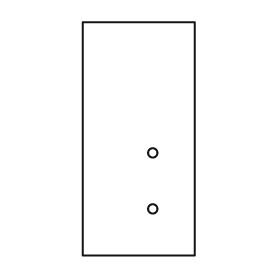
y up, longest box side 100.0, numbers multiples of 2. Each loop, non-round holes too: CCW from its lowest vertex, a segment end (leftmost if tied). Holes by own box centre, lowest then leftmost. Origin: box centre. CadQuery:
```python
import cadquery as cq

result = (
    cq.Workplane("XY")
    .moveTo(-24.0, -50.0)
    .lineTo(24.0, -50.0)
    .lineTo(24.0, 50.0)
    .lineTo(-24.0, 50.0)
    .close()
    .moveTo(6.0, -30.0)
    .circle(2.0)
    .moveTo(6.0, -6.0)
    .circle(2.0)
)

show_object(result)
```